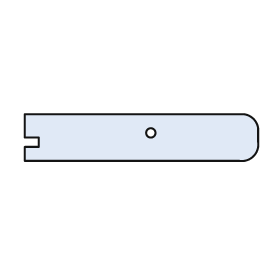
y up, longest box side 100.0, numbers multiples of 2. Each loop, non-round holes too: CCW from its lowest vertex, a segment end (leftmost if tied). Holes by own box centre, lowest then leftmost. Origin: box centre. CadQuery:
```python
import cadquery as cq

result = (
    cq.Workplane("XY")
    .moveTo(-50.0, -10.0)
    .lineTo(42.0, -10.0)
    .threePointArc((48.0, -8.0), (50.0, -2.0))
    .lineTo(50.0, 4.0)
    .threePointArc((48.0, 8.0), (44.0, 10.0))
    .lineTo(-50.0, 10.0)
    .lineTo(-50.0, 0.0)
    .lineTo(-44.0, 0.0)
    .lineTo(-44.0, -4.0)
    .lineTo(-50.0, -4.0)
    .close()
    .moveTo(4.0, 2.0)
    .circle(2.0)
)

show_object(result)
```